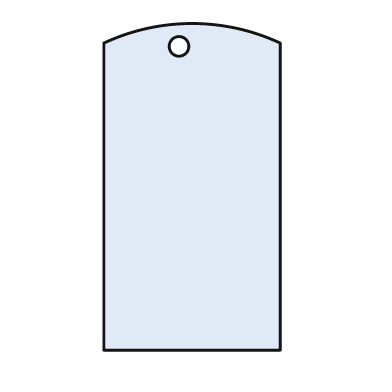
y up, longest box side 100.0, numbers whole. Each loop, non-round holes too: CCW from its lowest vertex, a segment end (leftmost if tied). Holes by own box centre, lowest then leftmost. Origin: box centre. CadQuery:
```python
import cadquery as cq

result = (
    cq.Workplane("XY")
    .moveTo(-27.0, -50.0)
    .lineTo(27.0, -50.0)
    .lineTo(27.0, 44.0)
    .threePointArc((0.0, 50.0), (-27.0, 44.0))
    .close()
    .moveTo(-4.0, 43.0)
    .circle(3.0)
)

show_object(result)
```